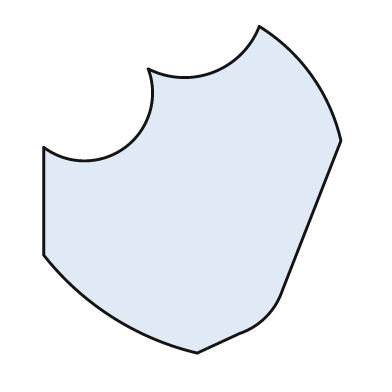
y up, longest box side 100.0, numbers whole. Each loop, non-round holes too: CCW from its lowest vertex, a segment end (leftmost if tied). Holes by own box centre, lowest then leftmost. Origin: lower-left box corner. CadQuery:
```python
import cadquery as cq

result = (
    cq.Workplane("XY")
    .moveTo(47.0, 0.0)
    .lineTo(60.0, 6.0)
    .threePointArc((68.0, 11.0), (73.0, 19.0))
    .lineTo(91.0, 65.0)
    .threePointArc((82.0, 85.0), (66.0, 100.0))
    .threePointArc((52.0, 86.0), (32.0, 87.0))
    .threePointArc((25.0, 63.0), (0.0, 63.0))
    .lineTo(0.0, 30.0)
    .threePointArc((21.0, 11.0), (47.0, 0.0))
    .close()
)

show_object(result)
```